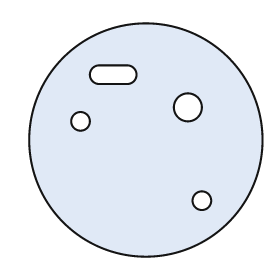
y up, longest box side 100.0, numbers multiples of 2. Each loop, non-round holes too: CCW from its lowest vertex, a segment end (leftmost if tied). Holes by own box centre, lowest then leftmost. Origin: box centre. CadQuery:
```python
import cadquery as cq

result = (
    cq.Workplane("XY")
    .moveTo(0.0, 0.0)
    .circle(50.0)
    .moveTo(24.0, -26.0)
    .circle(4.0)
    .moveTo(-28.0, 8.0)
    .circle(4.0)
    .moveTo(18.0, 14.0)
    .circle(6.0)
    .moveTo(-20.0, 24.0)
    .lineTo(-8.0, 24.0)
    .threePointArc((-4.0, 28.0), (-8.0, 32.0))
    .lineTo(-20.0, 32.0)
    .threePointArc((-24.0, 28.0), (-20.0, 24.0))
    .close()
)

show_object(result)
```